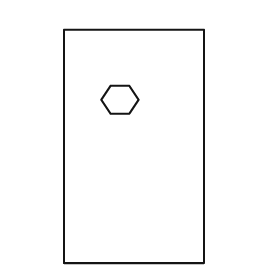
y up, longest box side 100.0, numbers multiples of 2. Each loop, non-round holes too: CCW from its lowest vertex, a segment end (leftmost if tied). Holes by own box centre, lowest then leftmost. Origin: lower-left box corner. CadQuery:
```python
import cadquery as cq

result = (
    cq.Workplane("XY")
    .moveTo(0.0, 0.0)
    .lineTo(60.0, 0.0)
    .lineTo(60.0, 100.0)
    .lineTo(0.0, 100.0)
    .close()
    .moveTo(20.0, 64.0)
    .lineTo(28.0, 64.0)
    .lineTo(32.0, 70.0)
    .lineTo(28.0, 76.0)
    .lineTo(20.0, 76.0)
    .lineTo(16.0, 70.0)
    .close()
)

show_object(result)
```